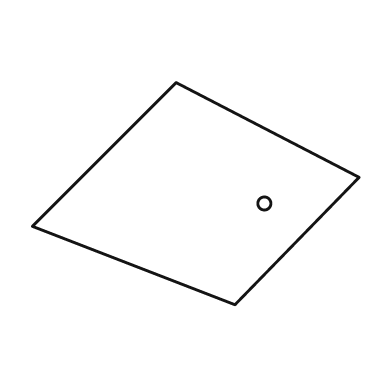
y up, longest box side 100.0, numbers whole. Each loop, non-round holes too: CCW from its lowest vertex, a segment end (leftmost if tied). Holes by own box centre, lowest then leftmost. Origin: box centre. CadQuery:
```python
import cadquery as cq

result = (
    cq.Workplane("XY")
    .moveTo(12.0, -34.0)
    .lineTo(50.0, 5.0)
    .lineTo(-6.0, 34.0)
    .lineTo(-50.0, -10.0)
    .close()
    .moveTo(21.0, -3.0)
    .circle(2.0)
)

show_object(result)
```